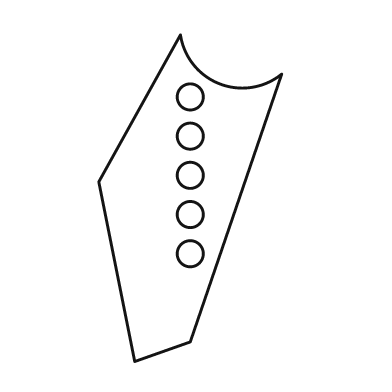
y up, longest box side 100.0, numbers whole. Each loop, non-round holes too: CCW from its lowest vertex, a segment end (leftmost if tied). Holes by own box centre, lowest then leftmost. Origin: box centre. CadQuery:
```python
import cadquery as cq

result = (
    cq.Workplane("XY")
    .moveTo(-17.0, -50.0)
    .lineTo(0.0, -44.0)
    .lineTo(28.0, 38.0)
    .threePointArc((9.0, 35.0), (-3.0, 50.0))
    .lineTo(-28.0, 5.0)
    .close()
    .moveTo(0.0, -17.0)
    .circle(4.0)
    .moveTo(0.0, -5.0)
    .circle(4.0)
    .moveTo(0.0, 7.0)
    .circle(4.0)
    .moveTo(0.0, 19.0)
    .circle(4.0)
    .moveTo(0.0, 31.0)
    .circle(4.0)
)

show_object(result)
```